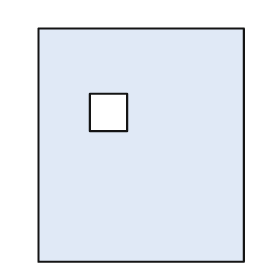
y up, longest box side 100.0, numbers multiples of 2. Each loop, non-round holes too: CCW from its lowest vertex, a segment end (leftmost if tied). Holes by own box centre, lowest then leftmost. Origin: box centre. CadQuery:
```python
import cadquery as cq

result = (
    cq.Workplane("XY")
    .moveTo(-44.0, -50.0)
    .lineTo(44.0, -50.0)
    .lineTo(44.0, 50.0)
    .lineTo(-44.0, 50.0)
    .close()
    .moveTo(-22.0, 6.0)
    .lineTo(-6.0, 6.0)
    .lineTo(-6.0, 22.0)
    .lineTo(-22.0, 22.0)
    .close()
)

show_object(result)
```